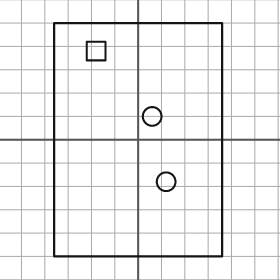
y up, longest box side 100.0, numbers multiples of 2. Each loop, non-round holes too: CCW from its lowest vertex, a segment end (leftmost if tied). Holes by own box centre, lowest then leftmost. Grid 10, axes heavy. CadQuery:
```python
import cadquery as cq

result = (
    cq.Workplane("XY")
    .moveTo(-36.0, -50.0)
    .lineTo(36.0, -50.0)
    .lineTo(36.0, 50.0)
    .lineTo(-36.0, 50.0)
    .close()
    .moveTo(12.0, -18.0)
    .circle(4.0)
    .moveTo(6.0, 10.0)
    .circle(4.0)
    .moveTo(-22.0, 34.0)
    .lineTo(-14.0, 34.0)
    .lineTo(-14.0, 42.0)
    .lineTo(-22.0, 42.0)
    .close()
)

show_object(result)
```